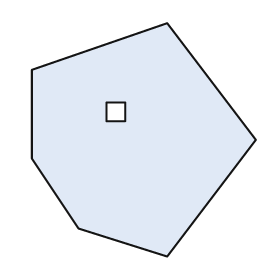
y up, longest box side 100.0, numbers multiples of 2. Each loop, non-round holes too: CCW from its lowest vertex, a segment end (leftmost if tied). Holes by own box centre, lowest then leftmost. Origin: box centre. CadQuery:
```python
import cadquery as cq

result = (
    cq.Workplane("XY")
    .moveTo(10.0, -50.0)
    .lineTo(48.0, 0.0)
    .lineTo(10.0, 50.0)
    .lineTo(-48.0, 30.0)
    .lineTo(-48.0, -8.0)
    .lineTo(-28.0, -38.0)
    .close()
    .moveTo(-16.0, 8.0)
    .lineTo(-8.0, 8.0)
    .lineTo(-8.0, 16.0)
    .lineTo(-16.0, 16.0)
    .close()
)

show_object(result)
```